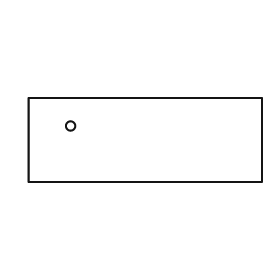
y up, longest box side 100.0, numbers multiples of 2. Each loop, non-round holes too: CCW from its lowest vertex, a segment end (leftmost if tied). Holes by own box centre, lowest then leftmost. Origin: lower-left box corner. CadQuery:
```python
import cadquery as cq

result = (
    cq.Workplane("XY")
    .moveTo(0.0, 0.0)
    .lineTo(100.0, 0.0)
    .lineTo(100.0, 36.0)
    .lineTo(0.0, 36.0)
    .close()
    .moveTo(18.0, 24.0)
    .circle(2.0)
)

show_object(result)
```